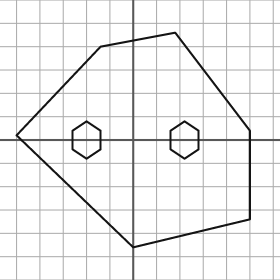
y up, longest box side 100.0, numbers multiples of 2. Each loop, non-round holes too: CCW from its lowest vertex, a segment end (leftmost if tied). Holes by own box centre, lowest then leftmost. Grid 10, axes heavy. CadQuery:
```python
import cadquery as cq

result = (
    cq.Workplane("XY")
    .moveTo(0.0, -46.0)
    .lineTo(50.0, -34.0)
    .lineTo(50.0, 4.0)
    .lineTo(18.0, 46.0)
    .lineTo(-14.0, 40.0)
    .lineTo(-50.0, 2.0)
    .close()
    .moveTo(-20.0, -8.0)
    .lineTo(-14.0, -4.0)
    .lineTo(-14.0, 4.0)
    .lineTo(-20.0, 8.0)
    .lineTo(-26.0, 4.0)
    .lineTo(-26.0, -4.0)
    .close()
    .moveTo(22.0, -8.0)
    .lineTo(28.0, -4.0)
    .lineTo(28.0, 4.0)
    .lineTo(22.0, 8.0)
    .lineTo(16.0, 4.0)
    .lineTo(16.0, -4.0)
    .close()
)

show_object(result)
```